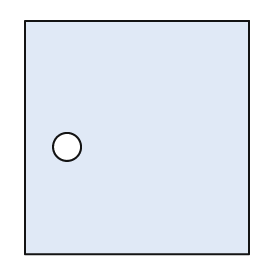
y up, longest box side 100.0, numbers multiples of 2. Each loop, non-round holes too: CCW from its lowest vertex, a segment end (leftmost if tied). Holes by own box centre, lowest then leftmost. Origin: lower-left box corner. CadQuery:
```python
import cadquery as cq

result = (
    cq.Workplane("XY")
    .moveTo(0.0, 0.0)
    .lineTo(96.0, 0.0)
    .lineTo(96.0, 100.0)
    .lineTo(0.0, 100.0)
    .close()
    .moveTo(18.0, 46.0)
    .circle(6.0)
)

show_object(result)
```